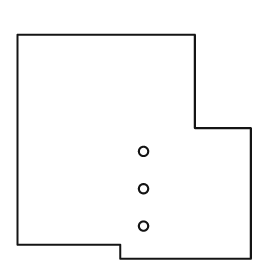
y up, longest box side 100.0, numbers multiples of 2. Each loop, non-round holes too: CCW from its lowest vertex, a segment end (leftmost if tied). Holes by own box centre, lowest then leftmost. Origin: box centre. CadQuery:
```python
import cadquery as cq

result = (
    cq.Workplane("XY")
    .moveTo(-6.0, -48.0)
    .lineTo(50.0, -48.0)
    .lineTo(50.0, 8.0)
    .lineTo(26.0, 8.0)
    .lineTo(26.0, 48.0)
    .lineTo(-50.0, 48.0)
    .lineTo(-50.0, -42.0)
    .lineTo(-6.0, -42.0)
    .close()
    .moveTo(4.0, -34.0)
    .circle(2.0)
    .moveTo(4.0, -18.0)
    .circle(2.0)
    .moveTo(4.0, -2.0)
    .circle(2.0)
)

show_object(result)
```